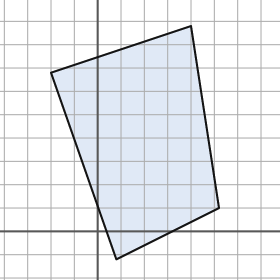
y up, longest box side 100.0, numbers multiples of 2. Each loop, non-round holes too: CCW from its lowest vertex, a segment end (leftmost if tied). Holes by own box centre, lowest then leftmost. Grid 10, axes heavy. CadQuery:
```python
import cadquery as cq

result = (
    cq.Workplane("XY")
    .moveTo(8.0, -12.0)
    .lineTo(52.0, 10.0)
    .lineTo(40.0, 88.0)
    .lineTo(-20.0, 68.0)
    .close()
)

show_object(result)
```